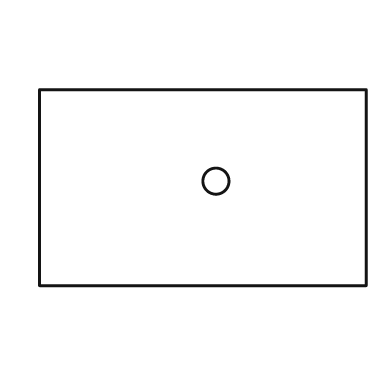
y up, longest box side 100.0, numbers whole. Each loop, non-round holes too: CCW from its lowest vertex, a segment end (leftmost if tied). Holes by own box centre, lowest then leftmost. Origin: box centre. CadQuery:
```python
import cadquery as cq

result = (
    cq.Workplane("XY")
    .moveTo(-50.0, -30.0)
    .lineTo(50.0, -30.0)
    .lineTo(50.0, 30.0)
    .lineTo(-50.0, 30.0)
    .close()
    .moveTo(4.0, 2.0)
    .circle(4.0)
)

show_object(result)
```